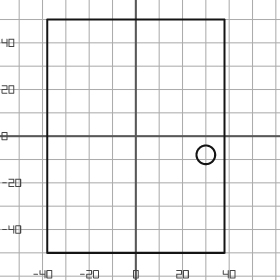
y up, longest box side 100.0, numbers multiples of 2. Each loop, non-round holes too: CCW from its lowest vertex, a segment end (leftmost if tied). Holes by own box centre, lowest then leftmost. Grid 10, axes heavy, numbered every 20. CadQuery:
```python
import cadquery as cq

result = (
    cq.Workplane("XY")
    .moveTo(-38.0, -50.0)
    .lineTo(38.0, -50.0)
    .lineTo(38.0, 50.0)
    .lineTo(-38.0, 50.0)
    .close()
    .moveTo(30.0, -8.0)
    .circle(4.0)
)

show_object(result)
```